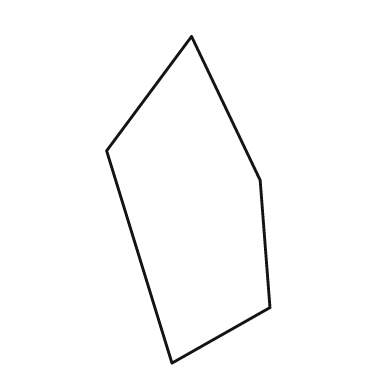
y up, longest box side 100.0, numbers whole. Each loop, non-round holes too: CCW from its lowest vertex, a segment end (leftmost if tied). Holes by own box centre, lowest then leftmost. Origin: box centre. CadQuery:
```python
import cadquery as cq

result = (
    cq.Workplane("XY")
    .moveTo(-5.0, -50.0)
    .lineTo(25.0, -33.0)
    .lineTo(22.0, 6.0)
    .lineTo(1.0, 50.0)
    .lineTo(-25.0, 15.0)
    .close()
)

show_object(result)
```